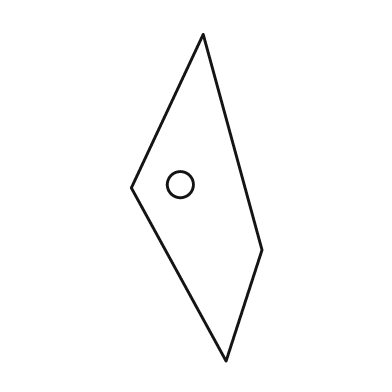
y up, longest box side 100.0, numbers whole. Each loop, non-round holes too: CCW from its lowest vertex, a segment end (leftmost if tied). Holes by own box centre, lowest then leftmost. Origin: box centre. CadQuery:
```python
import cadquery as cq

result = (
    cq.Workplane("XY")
    .moveTo(9.0, -50.0)
    .lineTo(20.0, -16.0)
    .lineTo(2.0, 50.0)
    .lineTo(-20.0, 3.0)
    .close()
    .moveTo(-5.0, 4.0)
    .circle(4.0)
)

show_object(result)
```